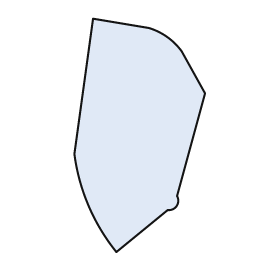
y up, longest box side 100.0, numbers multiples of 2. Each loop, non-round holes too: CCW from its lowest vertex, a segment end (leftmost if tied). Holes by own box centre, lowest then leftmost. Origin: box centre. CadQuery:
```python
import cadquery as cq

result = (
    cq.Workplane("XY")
    .moveTo(-10.0, -50.0)
    .lineTo(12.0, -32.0)
    .threePointArc((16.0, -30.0), (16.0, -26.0))
    .lineTo(28.0, 18.0)
    .lineTo(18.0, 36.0)
    .threePointArc((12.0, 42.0), (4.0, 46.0))
    .lineTo(-20.0, 50.0)
    .lineTo(-28.0, -8.0)
    .threePointArc((-22.0, -30.0), (-10.0, -50.0))
    .close()
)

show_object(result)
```